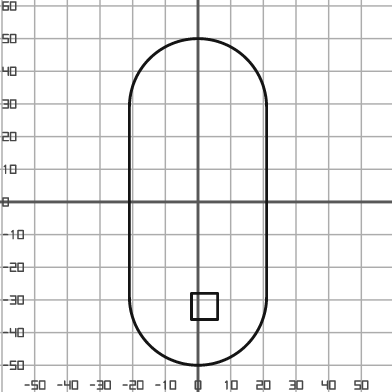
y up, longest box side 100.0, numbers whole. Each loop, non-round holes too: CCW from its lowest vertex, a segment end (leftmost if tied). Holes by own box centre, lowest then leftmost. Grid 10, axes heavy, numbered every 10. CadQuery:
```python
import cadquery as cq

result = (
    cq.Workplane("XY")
    .moveTo(-21.0, -29.0)
    .threePointArc((0.0, -50.0), (21.0, -29.0))
    .lineTo(21.0, 29.0)
    .threePointArc((0.0, 50.0), (-21.0, 29.0))
    .close()
    .moveTo(-2.0, -36.0)
    .lineTo(6.0, -36.0)
    .lineTo(6.0, -28.0)
    .lineTo(-2.0, -28.0)
    .close()
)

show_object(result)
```